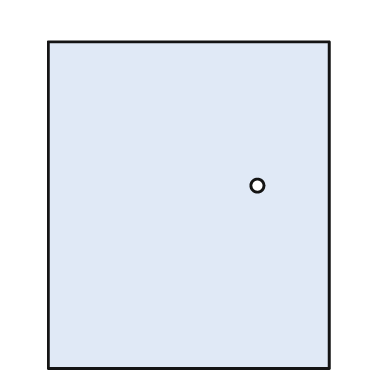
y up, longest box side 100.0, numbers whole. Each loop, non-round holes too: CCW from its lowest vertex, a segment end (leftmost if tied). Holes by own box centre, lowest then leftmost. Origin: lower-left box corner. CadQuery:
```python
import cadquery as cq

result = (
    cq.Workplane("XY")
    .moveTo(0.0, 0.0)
    .lineTo(86.0, 0.0)
    .lineTo(86.0, 100.0)
    .lineTo(0.0, 100.0)
    .close()
    .moveTo(64.0, 56.0)
    .circle(2.0)
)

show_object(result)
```